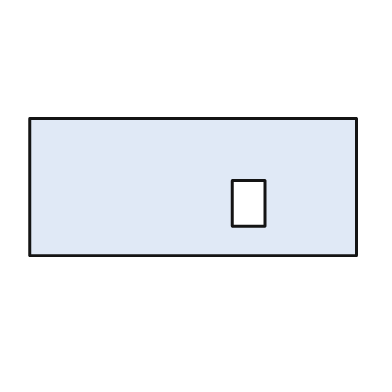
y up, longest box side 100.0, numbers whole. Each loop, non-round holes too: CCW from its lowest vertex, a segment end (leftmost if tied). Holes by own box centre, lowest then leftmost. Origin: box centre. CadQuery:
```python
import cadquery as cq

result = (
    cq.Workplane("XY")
    .moveTo(-50.0, -21.0)
    .lineTo(50.0, -21.0)
    .lineTo(50.0, 21.0)
    .lineTo(-50.0, 21.0)
    .close()
    .moveTo(12.0, -12.0)
    .lineTo(22.0, -12.0)
    .lineTo(22.0, 2.0)
    .lineTo(12.0, 2.0)
    .close()
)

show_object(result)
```